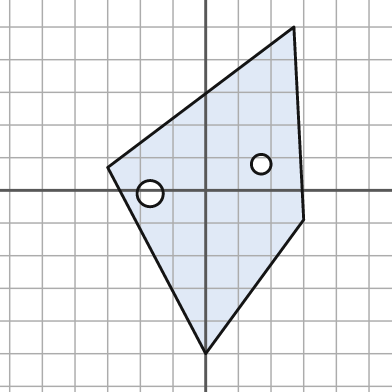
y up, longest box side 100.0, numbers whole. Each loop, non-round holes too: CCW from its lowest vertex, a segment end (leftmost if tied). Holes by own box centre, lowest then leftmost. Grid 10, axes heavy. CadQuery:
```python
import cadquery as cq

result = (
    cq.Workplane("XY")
    .moveTo(0.0, -50.0)
    .lineTo(30.0, -9.0)
    .lineTo(27.0, 50.0)
    .lineTo(-30.0, 7.0)
    .close()
    .moveTo(-17.0, -1.0)
    .circle(4.0)
    .moveTo(17.0, 8.0)
    .circle(3.0)
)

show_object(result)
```